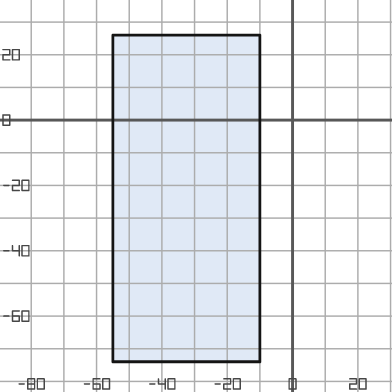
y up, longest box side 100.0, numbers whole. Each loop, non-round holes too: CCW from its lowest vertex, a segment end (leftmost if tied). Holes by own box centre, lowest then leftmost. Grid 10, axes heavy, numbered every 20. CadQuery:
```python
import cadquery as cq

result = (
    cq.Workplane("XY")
    .moveTo(-55.0, -74.0)
    .lineTo(-10.0, -74.0)
    .lineTo(-10.0, 26.0)
    .lineTo(-55.0, 26.0)
    .close()
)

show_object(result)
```